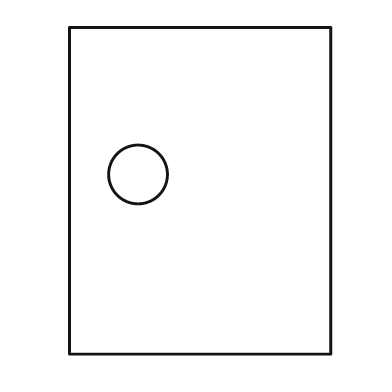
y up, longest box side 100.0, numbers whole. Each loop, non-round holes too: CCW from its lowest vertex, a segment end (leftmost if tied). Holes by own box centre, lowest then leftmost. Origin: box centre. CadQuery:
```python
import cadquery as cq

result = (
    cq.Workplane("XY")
    .moveTo(-40.0, -50.0)
    .lineTo(40.0, -50.0)
    .lineTo(40.0, 50.0)
    .lineTo(-40.0, 50.0)
    .close()
    .moveTo(-19.0, 5.0)
    .circle(9.0)
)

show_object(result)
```